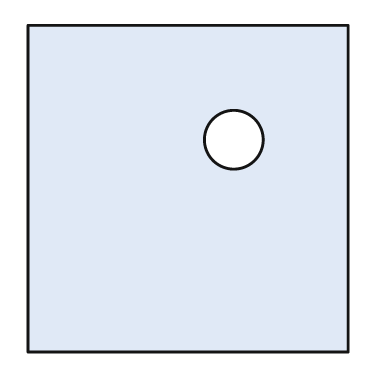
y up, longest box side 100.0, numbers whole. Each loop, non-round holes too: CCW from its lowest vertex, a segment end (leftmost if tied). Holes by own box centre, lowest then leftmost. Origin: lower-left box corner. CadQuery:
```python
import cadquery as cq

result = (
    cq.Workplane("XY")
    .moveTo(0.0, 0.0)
    .lineTo(98.0, 0.0)
    .lineTo(98.0, 100.0)
    .lineTo(0.0, 100.0)
    .close()
    .moveTo(63.0, 65.0)
    .circle(9.0)
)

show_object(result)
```